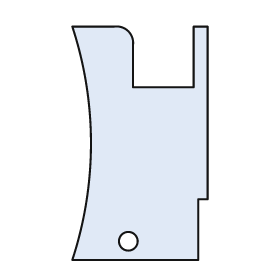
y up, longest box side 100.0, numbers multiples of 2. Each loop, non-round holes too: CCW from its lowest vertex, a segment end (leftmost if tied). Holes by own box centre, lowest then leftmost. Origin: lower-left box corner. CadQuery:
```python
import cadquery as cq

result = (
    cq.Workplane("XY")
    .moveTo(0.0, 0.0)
    .lineTo(54.0, 0.0)
    .lineTo(54.0, 26.0)
    .lineTo(58.0, 26.0)
    .lineTo(58.0, 100.0)
    .lineTo(52.0, 100.0)
    .lineTo(52.0, 74.0)
    .lineTo(26.0, 74.0)
    .lineTo(26.0, 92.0)
    .threePointArc((24.0, 98.0), (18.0, 100.0))
    .lineTo(0.0, 100.0)
    .threePointArc((8.0, 50.0), (0.0, 0.0))
    .close()
    .moveTo(24.0, 8.0)
    .circle(4.0)
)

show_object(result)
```